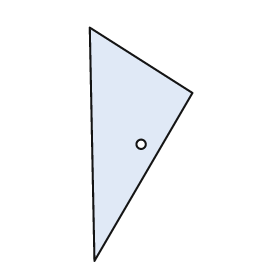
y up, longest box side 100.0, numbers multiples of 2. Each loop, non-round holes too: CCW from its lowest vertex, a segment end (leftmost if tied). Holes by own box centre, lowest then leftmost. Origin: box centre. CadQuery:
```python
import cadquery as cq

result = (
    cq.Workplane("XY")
    .moveTo(-20.0, -50.0)
    .lineTo(22.0, 22.0)
    .lineTo(-22.0, 50.0)
    .close()
    .moveTo(0.0, 0.0)
    .circle(2.0)
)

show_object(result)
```